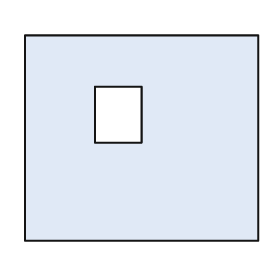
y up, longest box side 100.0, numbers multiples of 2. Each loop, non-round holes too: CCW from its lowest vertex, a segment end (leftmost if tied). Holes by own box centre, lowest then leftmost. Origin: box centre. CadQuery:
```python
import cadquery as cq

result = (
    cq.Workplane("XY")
    .moveTo(-50.0, -44.0)
    .lineTo(50.0, -44.0)
    .lineTo(50.0, 44.0)
    .lineTo(-50.0, 44.0)
    .close()
    .moveTo(-20.0, -2.0)
    .lineTo(0.0, -2.0)
    .lineTo(0.0, 22.0)
    .lineTo(-20.0, 22.0)
    .close()
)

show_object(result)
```